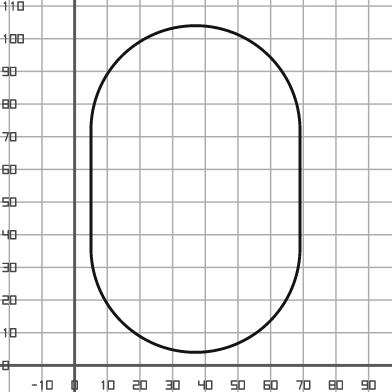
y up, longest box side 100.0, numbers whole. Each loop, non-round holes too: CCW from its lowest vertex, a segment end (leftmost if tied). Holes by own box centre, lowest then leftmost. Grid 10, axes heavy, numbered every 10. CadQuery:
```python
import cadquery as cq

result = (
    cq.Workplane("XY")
    .moveTo(5.0, 36.0)
    .threePointArc((37.0, 4.0), (69.0, 36.0))
    .lineTo(69.0, 72.0)
    .threePointArc((37.0, 104.0), (5.0, 72.0))
    .close()
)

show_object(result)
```